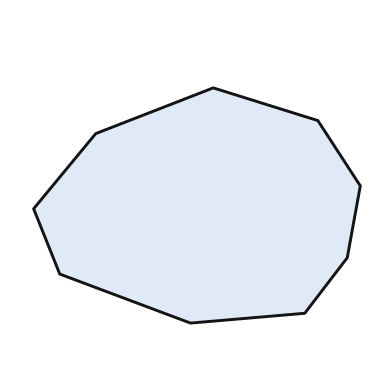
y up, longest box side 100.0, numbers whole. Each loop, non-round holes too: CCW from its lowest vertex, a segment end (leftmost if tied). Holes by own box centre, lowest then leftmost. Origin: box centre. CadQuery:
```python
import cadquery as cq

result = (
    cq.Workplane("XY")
    .moveTo(-2.0, -36.0)
    .lineTo(33.0, -33.0)
    .lineTo(46.0, -16.0)
    .lineTo(50.0, 6.0)
    .lineTo(37.0, 26.0)
    .lineTo(5.0, 36.0)
    .lineTo(-31.0, 22.0)
    .lineTo(-50.0, -1.0)
    .lineTo(-42.0, -21.0)
    .close()
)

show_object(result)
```